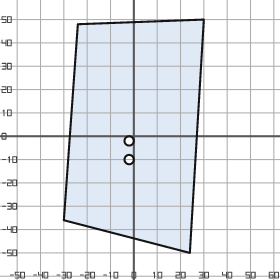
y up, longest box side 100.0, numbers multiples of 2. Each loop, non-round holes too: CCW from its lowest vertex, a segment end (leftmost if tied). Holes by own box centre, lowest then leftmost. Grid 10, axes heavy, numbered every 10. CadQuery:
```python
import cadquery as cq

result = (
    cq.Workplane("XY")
    .moveTo(24.0, -50.0)
    .lineTo(30.0, 50.0)
    .lineTo(-24.0, 48.0)
    .lineTo(-30.0, -36.0)
    .close()
    .moveTo(-2.0, -10.0)
    .circle(2.0)
    .moveTo(-2.0, -2.0)
    .circle(2.0)
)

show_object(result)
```